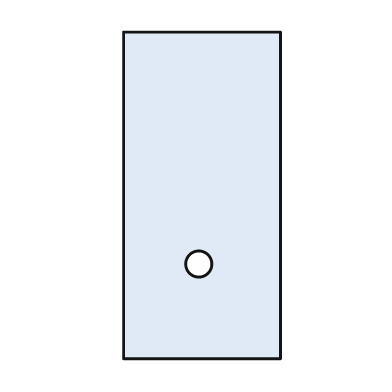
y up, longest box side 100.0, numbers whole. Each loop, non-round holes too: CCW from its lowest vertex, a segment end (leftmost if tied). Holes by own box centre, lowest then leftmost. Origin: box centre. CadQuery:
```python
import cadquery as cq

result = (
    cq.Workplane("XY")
    .moveTo(-24.0, -50.0)
    .lineTo(24.0, -50.0)
    .lineTo(24.0, 50.0)
    .lineTo(-24.0, 50.0)
    .close()
    .moveTo(-1.0, -21.0)
    .circle(4.0)
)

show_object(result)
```